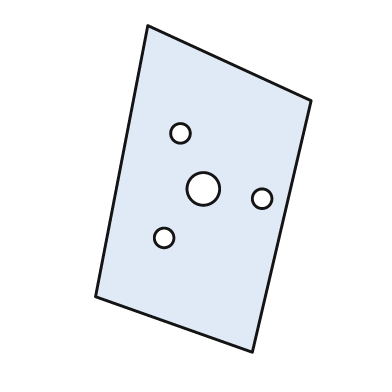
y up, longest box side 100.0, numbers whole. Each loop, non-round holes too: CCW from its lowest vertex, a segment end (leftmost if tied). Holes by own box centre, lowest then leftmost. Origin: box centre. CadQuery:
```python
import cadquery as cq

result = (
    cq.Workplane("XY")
    .moveTo(15.0, -50.0)
    .lineTo(33.0, 27.0)
    .lineTo(-17.0, 50.0)
    .lineTo(-33.0, -33.0)
    .close()
    .moveTo(-12.0, -15.0)
    .circle(3.0)
    .moveTo(18.0, -3.0)
    .circle(3.0)
    .moveTo(0.0, 0.0)
    .circle(5.0)
    .moveTo(-7.0, 17.0)
    .circle(3.0)
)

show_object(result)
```